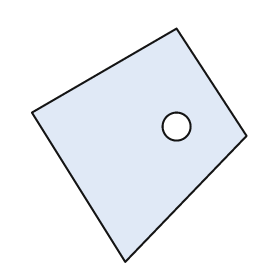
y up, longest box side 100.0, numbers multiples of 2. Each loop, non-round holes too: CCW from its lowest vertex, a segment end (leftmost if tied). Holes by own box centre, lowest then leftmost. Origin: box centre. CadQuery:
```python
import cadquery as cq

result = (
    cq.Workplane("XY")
    .moveTo(-6.0, -50.0)
    .lineTo(46.0, 4.0)
    .lineTo(16.0, 50.0)
    .lineTo(-46.0, 14.0)
    .close()
    .moveTo(16.0, 8.0)
    .circle(6.0)
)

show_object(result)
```